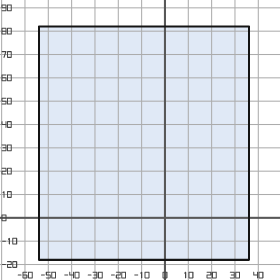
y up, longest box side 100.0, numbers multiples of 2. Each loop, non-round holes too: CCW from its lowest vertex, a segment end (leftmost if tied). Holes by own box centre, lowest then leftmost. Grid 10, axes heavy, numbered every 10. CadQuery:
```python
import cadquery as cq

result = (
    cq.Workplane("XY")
    .moveTo(-54.0, -18.0)
    .lineTo(36.0, -18.0)
    .lineTo(36.0, 82.0)
    .lineTo(-54.0, 82.0)
    .close()
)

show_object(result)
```